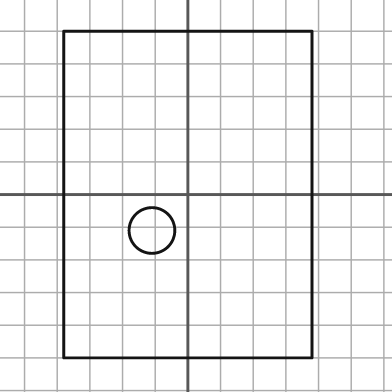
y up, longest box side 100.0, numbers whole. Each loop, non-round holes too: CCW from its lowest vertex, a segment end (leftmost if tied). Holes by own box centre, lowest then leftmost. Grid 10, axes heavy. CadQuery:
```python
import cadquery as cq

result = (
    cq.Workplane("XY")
    .moveTo(-38.0, -50.0)
    .lineTo(38.0, -50.0)
    .lineTo(38.0, 50.0)
    .lineTo(-38.0, 50.0)
    .close()
    .moveTo(-11.0, -11.0)
    .circle(7.0)
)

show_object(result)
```